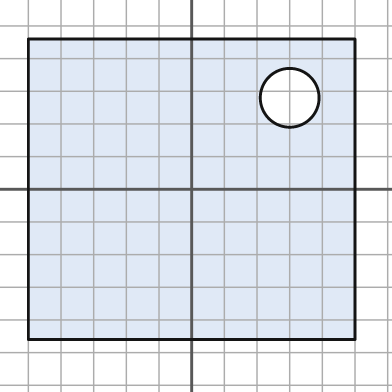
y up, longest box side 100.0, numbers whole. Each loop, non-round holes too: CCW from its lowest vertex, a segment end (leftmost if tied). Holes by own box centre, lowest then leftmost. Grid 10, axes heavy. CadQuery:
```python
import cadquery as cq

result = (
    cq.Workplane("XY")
    .moveTo(-50.0, -46.0)
    .lineTo(50.0, -46.0)
    .lineTo(50.0, 46.0)
    .lineTo(-50.0, 46.0)
    .close()
    .moveTo(30.0, 28.0)
    .circle(9.0)
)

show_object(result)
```